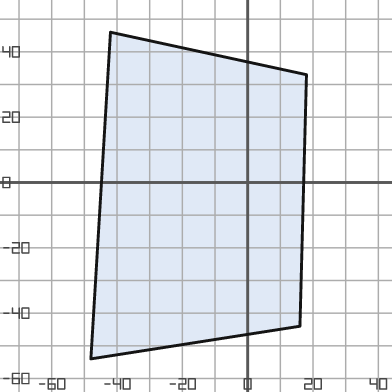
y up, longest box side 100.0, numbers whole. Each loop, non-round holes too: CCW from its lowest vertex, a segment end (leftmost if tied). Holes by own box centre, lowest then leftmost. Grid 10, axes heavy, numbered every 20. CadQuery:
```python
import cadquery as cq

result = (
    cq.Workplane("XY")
    .moveTo(-48.0, -54.0)
    .lineTo(16.0, -44.0)
    .lineTo(18.0, 33.0)
    .lineTo(-42.0, 46.0)
    .close()
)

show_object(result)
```